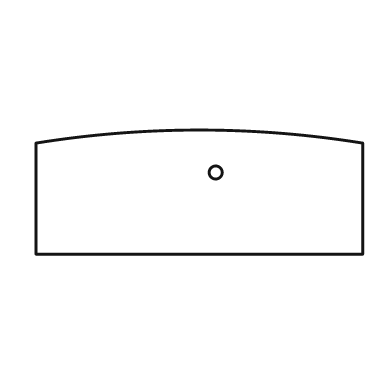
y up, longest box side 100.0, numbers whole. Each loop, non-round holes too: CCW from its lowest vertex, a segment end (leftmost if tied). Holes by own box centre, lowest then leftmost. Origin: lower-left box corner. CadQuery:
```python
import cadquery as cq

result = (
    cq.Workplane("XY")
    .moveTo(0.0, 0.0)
    .lineTo(100.0, 0.0)
    .lineTo(100.0, 34.0)
    .threePointArc((50.0, 38.0), (0.0, 34.0))
    .close()
    .moveTo(55.0, 25.0)
    .circle(2.0)
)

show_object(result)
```